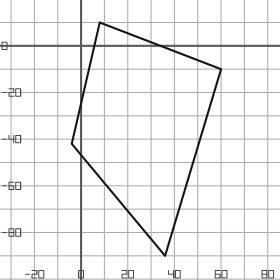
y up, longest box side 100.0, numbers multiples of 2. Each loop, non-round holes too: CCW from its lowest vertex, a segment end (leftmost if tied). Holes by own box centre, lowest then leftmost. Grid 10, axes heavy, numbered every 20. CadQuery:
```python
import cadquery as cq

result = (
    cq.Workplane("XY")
    .moveTo(36.0, -90.0)
    .lineTo(60.0, -10.0)
    .lineTo(8.0, 10.0)
    .lineTo(-4.0, -42.0)
    .close()
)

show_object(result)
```